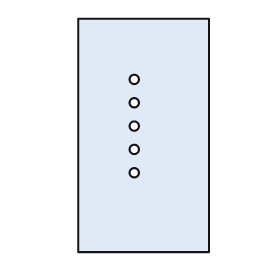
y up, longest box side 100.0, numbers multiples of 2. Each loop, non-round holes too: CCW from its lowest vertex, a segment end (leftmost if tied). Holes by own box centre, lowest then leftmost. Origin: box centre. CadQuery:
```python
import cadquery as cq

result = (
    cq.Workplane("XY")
    .moveTo(-28.0, -50.0)
    .lineTo(28.0, -50.0)
    .lineTo(28.0, 50.0)
    .lineTo(-28.0, 50.0)
    .close()
    .moveTo(-4.0, -16.0)
    .circle(2.0)
    .moveTo(-4.0, -6.0)
    .circle(2.0)
    .moveTo(-4.0, 4.0)
    .circle(2.0)
    .moveTo(-4.0, 14.0)
    .circle(2.0)
    .moveTo(-4.0, 24.0)
    .circle(2.0)
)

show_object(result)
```